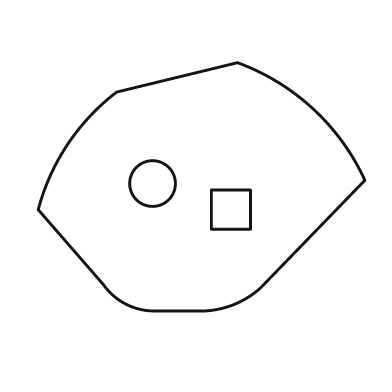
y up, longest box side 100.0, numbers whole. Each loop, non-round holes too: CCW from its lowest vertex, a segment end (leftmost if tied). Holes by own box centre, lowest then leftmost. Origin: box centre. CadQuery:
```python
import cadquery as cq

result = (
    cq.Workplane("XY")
    .moveTo(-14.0, -38.0)
    .lineTo(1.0, -38.0)
    .threePointArc((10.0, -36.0), (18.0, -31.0))
    .lineTo(50.0, 2.0)
    .threePointArc((34.0, 24.0), (11.0, 38.0))
    .lineTo(-26.0, 29.0)
    .threePointArc((-41.0, 13.0), (-50.0, -7.0))
    .lineTo(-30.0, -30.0)
    .threePointArc((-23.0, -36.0), (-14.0, -38.0))
    .close()
    .moveTo(3.0, -13.0)
    .lineTo(15.0, -13.0)
    .lineTo(15.0, -1.0)
    .lineTo(3.0, -1.0)
    .close()
    .moveTo(-15.0, 1.0)
    .circle(7.0)
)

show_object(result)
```